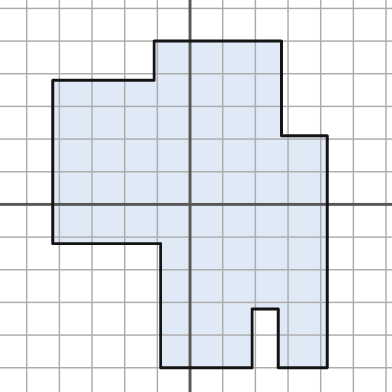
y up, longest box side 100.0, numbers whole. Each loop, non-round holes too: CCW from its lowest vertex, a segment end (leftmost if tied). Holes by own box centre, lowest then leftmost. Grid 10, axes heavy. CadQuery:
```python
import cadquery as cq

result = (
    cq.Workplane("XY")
    .moveTo(-9.0, -50.0)
    .lineTo(19.0, -50.0)
    .lineTo(19.0, -32.0)
    .lineTo(27.0, -32.0)
    .lineTo(27.0, -50.0)
    .lineTo(42.0, -50.0)
    .lineTo(42.0, 21.0)
    .lineTo(28.0, 21.0)
    .lineTo(28.0, 50.0)
    .lineTo(-11.0, 50.0)
    .lineTo(-11.0, 38.0)
    .lineTo(-42.0, 38.0)
    .lineTo(-42.0, -12.0)
    .lineTo(-9.0, -12.0)
    .close()
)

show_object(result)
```